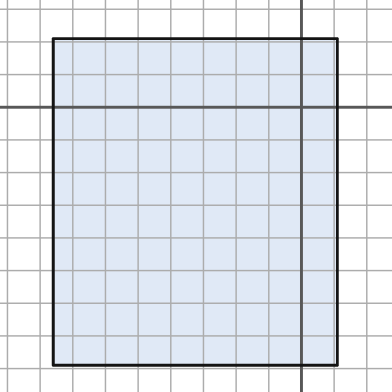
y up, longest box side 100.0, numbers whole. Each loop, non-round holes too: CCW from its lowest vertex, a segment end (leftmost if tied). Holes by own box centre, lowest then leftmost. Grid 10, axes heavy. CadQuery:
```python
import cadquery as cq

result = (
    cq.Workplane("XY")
    .moveTo(-76.0, -79.0)
    .lineTo(11.0, -79.0)
    .lineTo(11.0, 21.0)
    .lineTo(-76.0, 21.0)
    .close()
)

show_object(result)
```